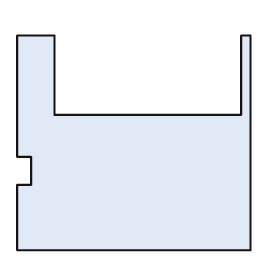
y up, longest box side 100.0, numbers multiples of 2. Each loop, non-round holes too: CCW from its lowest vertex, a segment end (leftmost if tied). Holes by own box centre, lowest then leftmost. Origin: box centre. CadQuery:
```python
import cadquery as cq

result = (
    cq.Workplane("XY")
    .moveTo(-50.0, -46.0)
    .lineTo(50.0, -46.0)
    .lineTo(50.0, 46.0)
    .lineTo(46.0, 46.0)
    .lineTo(46.0, 12.0)
    .lineTo(-34.0, 12.0)
    .lineTo(-34.0, 46.0)
    .lineTo(-50.0, 46.0)
    .lineTo(-50.0, -6.0)
    .lineTo(-44.0, -6.0)
    .lineTo(-44.0, -18.0)
    .lineTo(-50.0, -18.0)
    .close()
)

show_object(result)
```